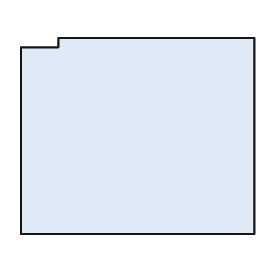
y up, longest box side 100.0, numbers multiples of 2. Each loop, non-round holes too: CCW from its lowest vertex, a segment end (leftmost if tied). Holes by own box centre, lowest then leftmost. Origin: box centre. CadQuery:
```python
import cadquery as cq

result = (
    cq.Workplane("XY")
    .moveTo(-50.0, -42.0)
    .lineTo(50.0, -42.0)
    .lineTo(50.0, 42.0)
    .lineTo(-34.0, 42.0)
    .lineTo(-34.0, 38.0)
    .lineTo(-50.0, 38.0)
    .close()
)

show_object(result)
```